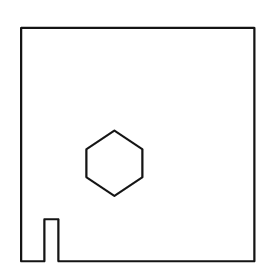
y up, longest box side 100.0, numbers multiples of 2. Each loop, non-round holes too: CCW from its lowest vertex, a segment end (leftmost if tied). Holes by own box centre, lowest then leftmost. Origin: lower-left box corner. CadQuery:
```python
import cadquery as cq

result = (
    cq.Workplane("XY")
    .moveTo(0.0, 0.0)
    .lineTo(10.0, 0.0)
    .lineTo(10.0, 18.0)
    .lineTo(16.0, 18.0)
    .lineTo(16.0, 0.0)
    .lineTo(100.0, 0.0)
    .lineTo(100.0, 100.0)
    .lineTo(0.0, 100.0)
    .close()
    .moveTo(40.0, 28.0)
    .lineTo(52.0, 36.0)
    .lineTo(52.0, 48.0)
    .lineTo(40.0, 56.0)
    .lineTo(28.0, 48.0)
    .lineTo(28.0, 36.0)
    .close()
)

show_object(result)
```